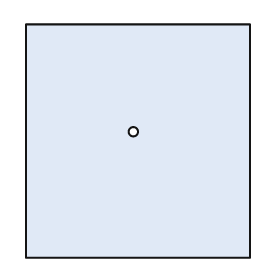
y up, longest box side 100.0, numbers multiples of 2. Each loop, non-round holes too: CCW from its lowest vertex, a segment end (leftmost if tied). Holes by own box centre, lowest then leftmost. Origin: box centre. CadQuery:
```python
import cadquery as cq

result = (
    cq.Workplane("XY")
    .moveTo(-48.0, -50.0)
    .lineTo(48.0, -50.0)
    .lineTo(48.0, 50.0)
    .lineTo(-48.0, 50.0)
    .close()
    .moveTo(-2.0, 4.0)
    .circle(2.0)
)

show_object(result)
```